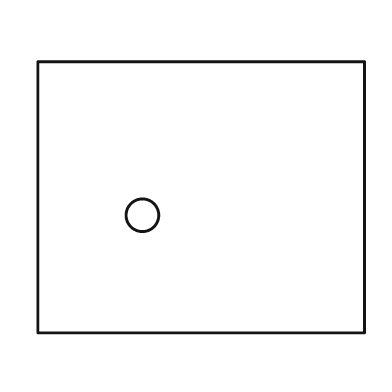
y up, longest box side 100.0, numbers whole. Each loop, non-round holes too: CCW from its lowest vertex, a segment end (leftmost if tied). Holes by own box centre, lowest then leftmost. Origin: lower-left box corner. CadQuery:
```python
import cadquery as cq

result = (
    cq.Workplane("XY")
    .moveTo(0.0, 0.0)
    .lineTo(100.0, 0.0)
    .lineTo(100.0, 83.0)
    .lineTo(0.0, 83.0)
    .close()
    .moveTo(32.0, 36.0)
    .circle(5.0)
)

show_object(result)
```